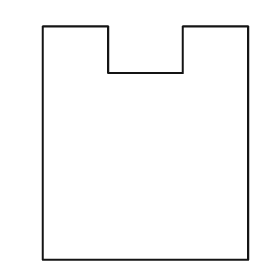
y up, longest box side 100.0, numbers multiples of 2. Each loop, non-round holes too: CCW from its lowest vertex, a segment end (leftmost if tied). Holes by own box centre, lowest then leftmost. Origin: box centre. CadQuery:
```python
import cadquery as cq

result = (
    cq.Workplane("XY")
    .moveTo(-44.0, -50.0)
    .lineTo(44.0, -50.0)
    .lineTo(44.0, 50.0)
    .lineTo(16.0, 50.0)
    .lineTo(16.0, 30.0)
    .lineTo(-16.0, 30.0)
    .lineTo(-16.0, 50.0)
    .lineTo(-44.0, 50.0)
    .close()
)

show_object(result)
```